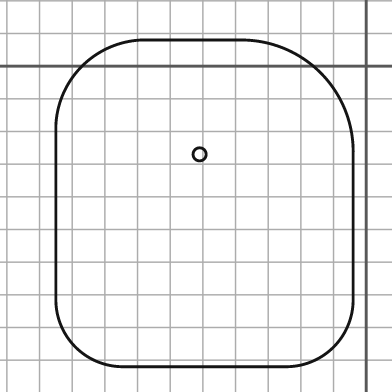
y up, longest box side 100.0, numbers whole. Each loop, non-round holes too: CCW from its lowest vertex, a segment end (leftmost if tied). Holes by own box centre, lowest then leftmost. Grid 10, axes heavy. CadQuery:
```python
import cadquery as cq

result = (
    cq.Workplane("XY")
    .moveTo(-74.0, -92.0)
    .lineTo(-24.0, -92.0)
    .threePointArc((-10.0, -86.0), (-4.0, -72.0))
    .lineTo(-4.0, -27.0)
    .threePointArc((-14.0, -2.0), (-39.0, 8.0))
    .lineTo(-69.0, 8.0)
    .threePointArc((-87.0, 0.0), (-95.0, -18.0))
    .lineTo(-95.0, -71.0)
    .threePointArc((-89.0, -86.0), (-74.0, -92.0))
    .close()
    .moveTo(-51.0, -27.0)
    .circle(2.0)
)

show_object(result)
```